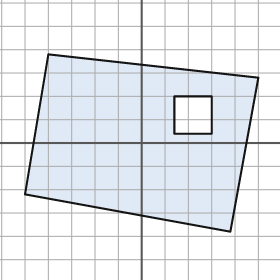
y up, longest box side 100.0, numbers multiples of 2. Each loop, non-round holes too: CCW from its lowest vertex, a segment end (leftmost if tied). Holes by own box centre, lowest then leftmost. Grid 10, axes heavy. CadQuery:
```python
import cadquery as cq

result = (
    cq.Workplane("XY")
    .moveTo(38.0, -38.0)
    .lineTo(50.0, 28.0)
    .lineTo(-40.0, 38.0)
    .lineTo(-50.0, -22.0)
    .close()
    .moveTo(14.0, 4.0)
    .lineTo(30.0, 4.0)
    .lineTo(30.0, 20.0)
    .lineTo(14.0, 20.0)
    .close()
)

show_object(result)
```